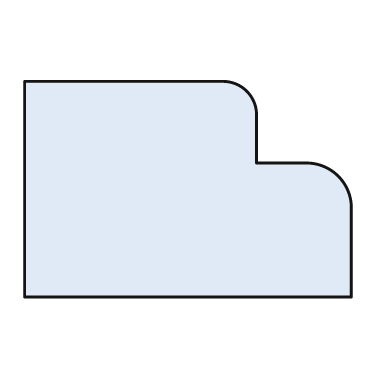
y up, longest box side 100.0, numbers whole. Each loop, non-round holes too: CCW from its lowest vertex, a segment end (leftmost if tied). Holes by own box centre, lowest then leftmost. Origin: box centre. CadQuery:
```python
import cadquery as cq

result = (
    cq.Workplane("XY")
    .moveTo(-50.0, -33.0)
    .lineTo(50.0, -33.0)
    .lineTo(50.0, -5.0)
    .threePointArc((46.0, 4.0), (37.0, 8.0))
    .lineTo(21.0, 8.0)
    .lineTo(21.0, 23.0)
    .threePointArc((18.0, 30.0), (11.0, 33.0))
    .lineTo(-50.0, 33.0)
    .close()
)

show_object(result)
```